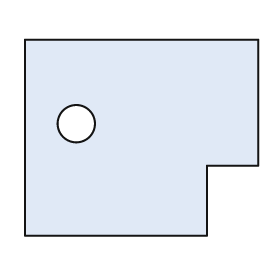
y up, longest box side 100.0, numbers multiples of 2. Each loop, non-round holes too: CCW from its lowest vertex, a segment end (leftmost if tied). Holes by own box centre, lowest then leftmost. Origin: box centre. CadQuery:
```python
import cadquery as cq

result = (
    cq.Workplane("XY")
    .moveTo(-50.0, -42.0)
    .lineTo(28.0, -42.0)
    .lineTo(28.0, -12.0)
    .lineTo(50.0, -12.0)
    .lineTo(50.0, 42.0)
    .lineTo(-50.0, 42.0)
    .close()
    .moveTo(-28.0, 6.0)
    .circle(8.0)
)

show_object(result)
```